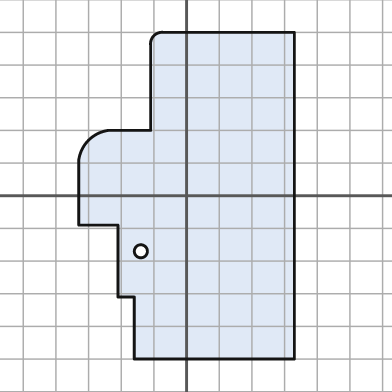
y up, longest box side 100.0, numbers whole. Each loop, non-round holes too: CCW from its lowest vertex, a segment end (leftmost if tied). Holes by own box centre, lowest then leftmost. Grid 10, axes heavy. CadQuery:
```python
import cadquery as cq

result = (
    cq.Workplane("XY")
    .moveTo(-16.0, -50.0)
    .lineTo(33.0, -50.0)
    .lineTo(33.0, 50.0)
    .lineTo(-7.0, 50.0)
    .threePointArc((-10.0, 49.0), (-11.0, 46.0))
    .lineTo(-11.0, 20.0)
    .lineTo(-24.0, 20.0)
    .threePointArc((-30.0, 17.0), (-33.0, 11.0))
    .lineTo(-33.0, -9.0)
    .lineTo(-21.0, -9.0)
    .lineTo(-21.0, -31.0)
    .lineTo(-16.0, -31.0)
    .close()
    .moveTo(-14.0, -17.0)
    .circle(2.0)
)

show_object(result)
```